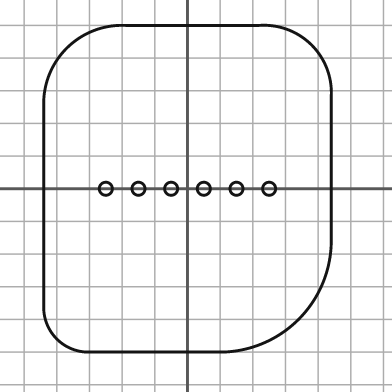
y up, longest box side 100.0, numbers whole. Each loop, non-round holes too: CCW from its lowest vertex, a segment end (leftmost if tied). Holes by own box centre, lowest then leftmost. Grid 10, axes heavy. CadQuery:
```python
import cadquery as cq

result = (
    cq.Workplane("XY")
    .moveTo(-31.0, -50.0)
    .lineTo(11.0, -50.0)
    .threePointArc((34.0, -40.0), (44.0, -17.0))
    .lineTo(44.0, 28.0)
    .threePointArc((38.0, 44.0), (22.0, 50.0))
    .lineTo(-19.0, 50.0)
    .threePointArc((-37.0, 43.0), (-44.0, 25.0))
    .lineTo(-44.0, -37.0)
    .threePointArc((-40.0, -46.0), (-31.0, -50.0))
    .close()
    .moveTo(-25.0, 0.0)
    .circle(2.0)
    .moveTo(-15.0, 0.0)
    .circle(2.0)
    .moveTo(-5.0, 0.0)
    .circle(2.0)
    .moveTo(5.0, 0.0)
    .circle(2.0)
    .moveTo(15.0, 0.0)
    .circle(2.0)
    .moveTo(25.0, 0.0)
    .circle(2.0)
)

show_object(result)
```